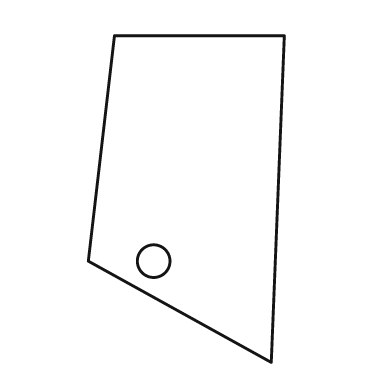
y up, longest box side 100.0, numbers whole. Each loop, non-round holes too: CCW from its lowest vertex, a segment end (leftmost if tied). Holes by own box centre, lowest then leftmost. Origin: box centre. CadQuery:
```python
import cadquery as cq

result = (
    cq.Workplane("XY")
    .moveTo(26.0, -50.0)
    .lineTo(30.0, 50.0)
    .lineTo(-22.0, 50.0)
    .lineTo(-30.0, -19.0)
    .close()
    .moveTo(-10.0, -19.0)
    .circle(5.0)
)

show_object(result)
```